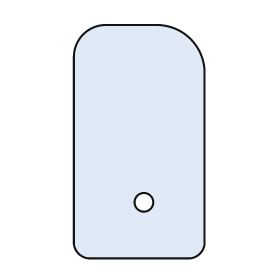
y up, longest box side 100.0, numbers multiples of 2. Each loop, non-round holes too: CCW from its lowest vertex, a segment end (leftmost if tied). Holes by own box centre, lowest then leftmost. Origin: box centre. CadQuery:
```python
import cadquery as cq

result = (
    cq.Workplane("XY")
    .moveTo(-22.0, -50.0)
    .lineTo(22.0, -50.0)
    .threePointArc((26.0, -48.0), (28.0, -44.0))
    .lineTo(28.0, 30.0)
    .threePointArc((22.0, 44.0), (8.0, 50.0))
    .lineTo(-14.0, 50.0)
    .threePointArc((-24.0, 46.0), (-28.0, 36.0))
    .lineTo(-28.0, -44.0)
    .threePointArc((-26.0, -48.0), (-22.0, -50.0))
    .close()
    .moveTo(2.0, -26.0)
    .circle(4.0)
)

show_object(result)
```